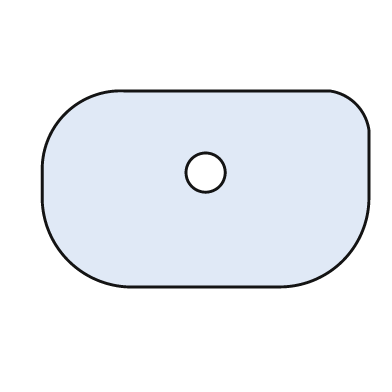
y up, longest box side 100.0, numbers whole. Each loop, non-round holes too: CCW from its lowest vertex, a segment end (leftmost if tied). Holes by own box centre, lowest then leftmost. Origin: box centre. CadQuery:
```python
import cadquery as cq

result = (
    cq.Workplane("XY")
    .moveTo(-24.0, -30.0)
    .lineTo(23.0, -30.0)
    .threePointArc((42.0, -22.0), (50.0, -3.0))
    .lineTo(50.0, 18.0)
    .threePointArc((46.0, 26.0), (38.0, 30.0))
    .lineTo(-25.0, 30.0)
    .threePointArc((-43.0, 23.0), (-50.0, 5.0))
    .lineTo(-50.0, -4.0)
    .threePointArc((-42.0, -22.0), (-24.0, -30.0))
    .close()
    .moveTo(0.0, 5.0)
    .circle(6.0)
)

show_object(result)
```